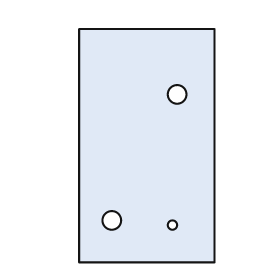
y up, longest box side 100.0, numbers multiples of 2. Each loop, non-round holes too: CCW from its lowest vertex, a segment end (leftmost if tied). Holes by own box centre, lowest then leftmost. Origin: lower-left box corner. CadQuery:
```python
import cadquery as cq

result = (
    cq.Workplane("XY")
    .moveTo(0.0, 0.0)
    .lineTo(58.0, 0.0)
    .lineTo(58.0, 100.0)
    .lineTo(0.0, 100.0)
    .close()
    .moveTo(40.0, 16.0)
    .circle(2.0)
    .moveTo(14.0, 18.0)
    .circle(4.0)
    .moveTo(42.0, 72.0)
    .circle(4.0)
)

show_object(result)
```